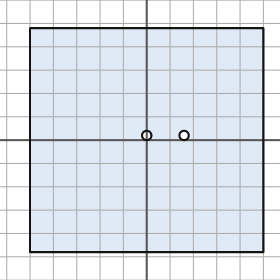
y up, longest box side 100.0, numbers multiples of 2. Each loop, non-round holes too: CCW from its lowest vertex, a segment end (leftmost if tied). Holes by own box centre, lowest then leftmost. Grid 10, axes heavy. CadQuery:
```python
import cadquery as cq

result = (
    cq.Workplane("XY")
    .moveTo(-50.0, -48.0)
    .lineTo(50.0, -48.0)
    .lineTo(50.0, 48.0)
    .lineTo(-50.0, 48.0)
    .close()
    .moveTo(0.0, 2.0)
    .circle(2.0)
    .moveTo(16.0, 2.0)
    .circle(2.0)
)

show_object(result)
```